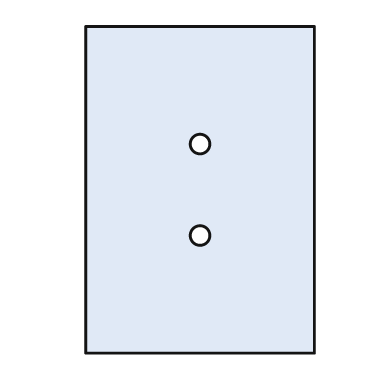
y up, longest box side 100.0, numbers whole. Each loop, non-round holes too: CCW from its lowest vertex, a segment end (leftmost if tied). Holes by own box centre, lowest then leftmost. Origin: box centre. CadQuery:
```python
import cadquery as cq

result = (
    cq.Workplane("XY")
    .moveTo(-35.0, -50.0)
    .lineTo(35.0, -50.0)
    .lineTo(35.0, 50.0)
    .lineTo(-35.0, 50.0)
    .close()
    .moveTo(0.0, -14.0)
    .circle(3.0)
    .moveTo(0.0, 14.0)
    .circle(3.0)
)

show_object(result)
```